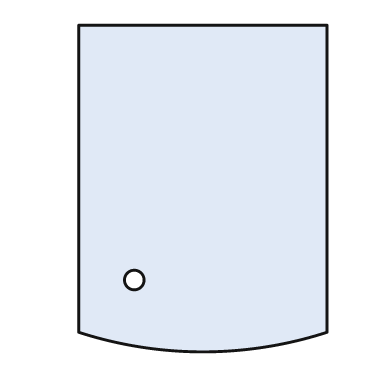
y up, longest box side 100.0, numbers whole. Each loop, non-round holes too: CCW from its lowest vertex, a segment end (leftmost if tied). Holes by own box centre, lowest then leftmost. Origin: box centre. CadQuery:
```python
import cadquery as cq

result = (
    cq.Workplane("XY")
    .moveTo(-38.0, -44.0)
    .threePointArc((0.0, -50.0), (38.0, -44.0))
    .lineTo(38.0, 50.0)
    .lineTo(-38.0, 50.0)
    .close()
    .moveTo(-21.0, -28.0)
    .circle(3.0)
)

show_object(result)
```